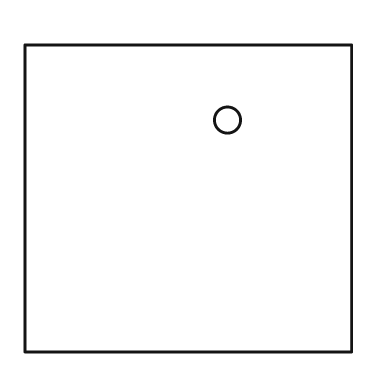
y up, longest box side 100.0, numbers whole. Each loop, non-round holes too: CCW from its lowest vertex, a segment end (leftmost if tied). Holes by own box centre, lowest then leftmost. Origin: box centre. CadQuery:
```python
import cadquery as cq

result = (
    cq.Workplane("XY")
    .moveTo(-50.0, -47.0)
    .lineTo(50.0, -47.0)
    .lineTo(50.0, 47.0)
    .lineTo(-50.0, 47.0)
    .close()
    .moveTo(12.0, 24.0)
    .circle(4.0)
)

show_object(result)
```